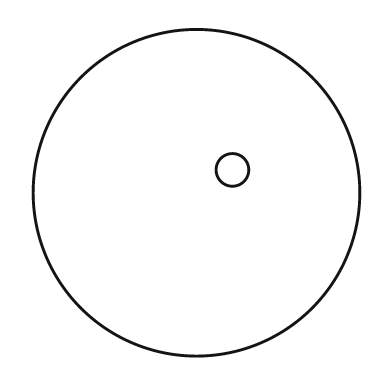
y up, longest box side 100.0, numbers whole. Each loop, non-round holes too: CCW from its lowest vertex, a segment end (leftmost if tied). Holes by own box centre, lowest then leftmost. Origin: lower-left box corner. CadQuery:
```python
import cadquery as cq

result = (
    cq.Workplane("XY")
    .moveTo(50.0, 50.0)
    .circle(50.0)
    .moveTo(61.0, 57.0)
    .circle(5.0)
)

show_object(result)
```